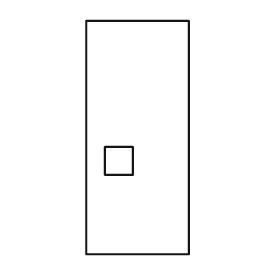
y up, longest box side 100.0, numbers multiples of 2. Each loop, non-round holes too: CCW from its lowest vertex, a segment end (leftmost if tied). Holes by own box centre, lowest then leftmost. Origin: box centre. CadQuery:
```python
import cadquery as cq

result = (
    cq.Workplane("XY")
    .moveTo(-22.0, -50.0)
    .lineTo(22.0, -50.0)
    .lineTo(22.0, 50.0)
    .lineTo(-22.0, 50.0)
    .close()
    .moveTo(-14.0, -16.0)
    .lineTo(-2.0, -16.0)
    .lineTo(-2.0, -4.0)
    .lineTo(-14.0, -4.0)
    .close()
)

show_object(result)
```